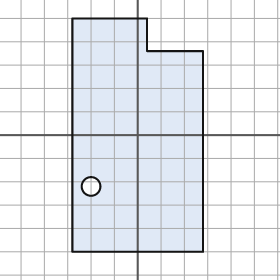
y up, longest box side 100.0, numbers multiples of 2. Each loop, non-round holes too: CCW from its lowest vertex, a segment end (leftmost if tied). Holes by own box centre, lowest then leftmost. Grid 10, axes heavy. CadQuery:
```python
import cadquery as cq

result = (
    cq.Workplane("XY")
    .moveTo(-28.0, -50.0)
    .lineTo(28.0, -50.0)
    .lineTo(28.0, 36.0)
    .lineTo(4.0, 36.0)
    .lineTo(4.0, 50.0)
    .lineTo(-28.0, 50.0)
    .close()
    .moveTo(-20.0, -22.0)
    .circle(4.0)
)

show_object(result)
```